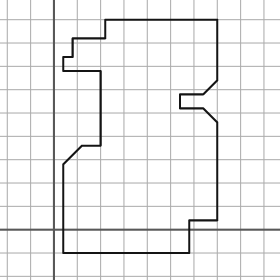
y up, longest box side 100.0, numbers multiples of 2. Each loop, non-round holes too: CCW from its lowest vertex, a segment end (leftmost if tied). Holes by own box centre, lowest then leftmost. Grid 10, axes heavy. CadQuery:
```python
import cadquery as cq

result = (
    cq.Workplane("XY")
    .moveTo(4.0, -10.0)
    .lineTo(58.0, -10.0)
    .lineTo(58.0, 4.0)
    .lineTo(70.0, 4.0)
    .lineTo(70.0, 46.0)
    .lineTo(64.0, 52.0)
    .lineTo(54.0, 52.0)
    .lineTo(54.0, 58.0)
    .lineTo(64.0, 58.0)
    .lineTo(70.0, 64.0)
    .lineTo(70.0, 90.0)
    .lineTo(22.0, 90.0)
    .lineTo(22.0, 82.0)
    .lineTo(8.0, 82.0)
    .lineTo(8.0, 74.0)
    .lineTo(4.0, 74.0)
    .lineTo(4.0, 68.0)
    .lineTo(20.0, 68.0)
    .lineTo(20.0, 36.0)
    .lineTo(12.0, 36.0)
    .lineTo(4.0, 28.0)
    .close()
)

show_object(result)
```